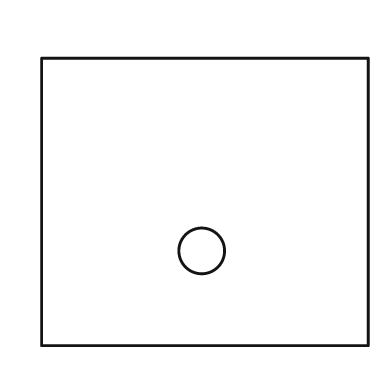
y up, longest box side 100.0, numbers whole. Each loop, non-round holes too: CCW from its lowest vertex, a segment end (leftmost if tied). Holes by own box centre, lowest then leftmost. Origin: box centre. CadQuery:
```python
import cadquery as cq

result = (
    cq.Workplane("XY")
    .moveTo(-50.0, -44.0)
    .lineTo(50.0, -44.0)
    .lineTo(50.0, 44.0)
    .lineTo(-50.0, 44.0)
    .close()
    .moveTo(-1.0, -15.0)
    .circle(7.0)
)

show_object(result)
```